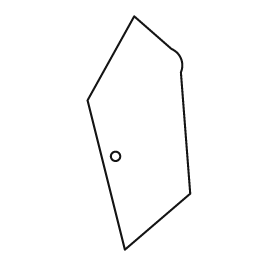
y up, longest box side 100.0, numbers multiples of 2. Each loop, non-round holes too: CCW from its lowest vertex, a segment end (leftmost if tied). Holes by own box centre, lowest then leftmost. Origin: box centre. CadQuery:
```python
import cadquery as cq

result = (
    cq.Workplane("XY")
    .moveTo(-6.0, -50.0)
    .lineTo(22.0, -26.0)
    .lineTo(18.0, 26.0)
    .threePointArc((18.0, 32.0), (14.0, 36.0))
    .lineTo(-2.0, 50.0)
    .lineTo(-22.0, 14.0)
    .close()
    .moveTo(-10.0, -10.0)
    .circle(2.0)
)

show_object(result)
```